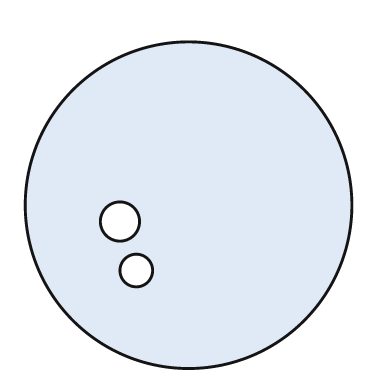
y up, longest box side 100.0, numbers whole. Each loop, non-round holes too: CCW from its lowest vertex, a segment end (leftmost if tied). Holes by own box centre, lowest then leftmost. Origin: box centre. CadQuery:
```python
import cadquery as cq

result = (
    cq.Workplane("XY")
    .moveTo(0.0, 0.0)
    .circle(50.0)
    .moveTo(-16.0, -20.0)
    .circle(5.0)
    .moveTo(-21.0, -5.0)
    .circle(6.0)
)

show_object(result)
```